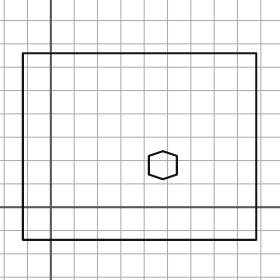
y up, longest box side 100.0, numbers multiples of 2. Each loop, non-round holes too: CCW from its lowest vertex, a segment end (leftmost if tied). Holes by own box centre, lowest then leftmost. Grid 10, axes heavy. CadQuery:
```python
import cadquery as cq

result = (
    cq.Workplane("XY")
    .moveTo(-12.0, -14.0)
    .lineTo(88.0, -14.0)
    .lineTo(88.0, 66.0)
    .lineTo(-12.0, 66.0)
    .close()
    .moveTo(48.0, 12.0)
    .lineTo(54.0, 14.0)
    .lineTo(54.0, 22.0)
    .lineTo(48.0, 24.0)
    .lineTo(42.0, 22.0)
    .lineTo(42.0, 14.0)
    .close()
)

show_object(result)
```